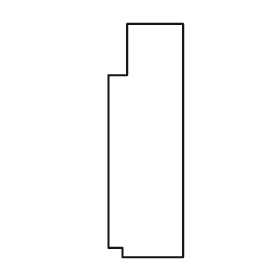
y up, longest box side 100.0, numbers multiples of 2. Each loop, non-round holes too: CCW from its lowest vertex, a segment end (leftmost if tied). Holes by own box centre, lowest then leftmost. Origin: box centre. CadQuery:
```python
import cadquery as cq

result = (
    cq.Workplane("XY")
    .moveTo(-10.0, -50.0)
    .lineTo(16.0, -50.0)
    .lineTo(16.0, 50.0)
    .lineTo(-8.0, 50.0)
    .lineTo(-8.0, 28.0)
    .lineTo(-16.0, 28.0)
    .lineTo(-16.0, -46.0)
    .lineTo(-10.0, -46.0)
    .close()
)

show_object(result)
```